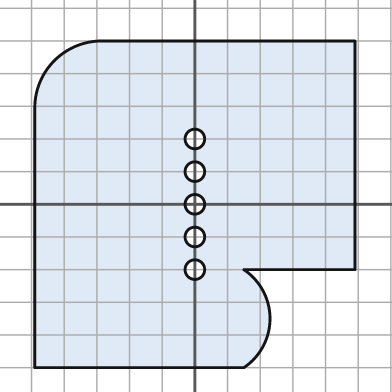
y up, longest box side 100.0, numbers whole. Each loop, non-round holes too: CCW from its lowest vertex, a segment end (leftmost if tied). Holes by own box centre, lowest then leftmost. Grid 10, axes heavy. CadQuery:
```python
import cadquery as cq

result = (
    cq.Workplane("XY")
    .moveTo(-49.0, -50.0)
    .lineTo(15.0, -50.0)
    .threePointArc((23.0, -35.0), (15.0, -20.0))
    .lineTo(49.0, -20.0)
    .lineTo(49.0, 50.0)
    .lineTo(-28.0, 50.0)
    .threePointArc((-43.0, 44.0), (-49.0, 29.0))
    .close()
    .moveTo(0.0, -20.0)
    .circle(3.0)
    .moveTo(0.0, -10.0)
    .circle(3.0)
    .moveTo(0.0, 0.0)
    .circle(3.0)
    .moveTo(0.0, 10.0)
    .circle(3.0)
    .moveTo(0.0, 20.0)
    .circle(3.0)
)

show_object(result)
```